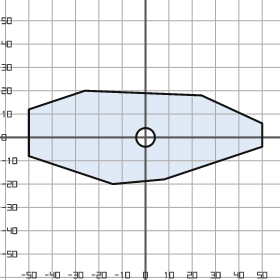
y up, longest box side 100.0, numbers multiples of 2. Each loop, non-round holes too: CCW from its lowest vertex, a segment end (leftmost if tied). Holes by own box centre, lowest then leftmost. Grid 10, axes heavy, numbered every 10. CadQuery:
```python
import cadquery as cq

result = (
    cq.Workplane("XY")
    .moveTo(-14.0, -20.0)
    .lineTo(8.0, -18.0)
    .lineTo(50.0, -4.0)
    .lineTo(50.0, 6.0)
    .lineTo(24.0, 18.0)
    .lineTo(-26.0, 20.0)
    .lineTo(-50.0, 12.0)
    .lineTo(-50.0, -8.0)
    .close()
    .moveTo(0.0, 0.0)
    .circle(4.0)
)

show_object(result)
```